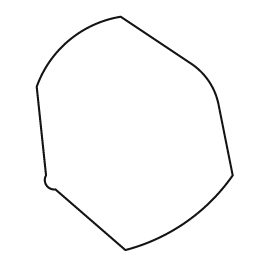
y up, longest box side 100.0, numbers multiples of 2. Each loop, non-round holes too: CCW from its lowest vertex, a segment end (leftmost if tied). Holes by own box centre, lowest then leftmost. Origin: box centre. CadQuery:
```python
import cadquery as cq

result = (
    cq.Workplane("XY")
    .moveTo(-4.0, -50.0)
    .threePointArc((22.0, -38.0), (42.0, -18.0))
    .lineTo(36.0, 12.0)
    .threePointArc((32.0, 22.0), (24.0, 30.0))
    .lineTo(-6.0, 50.0)
    .threePointArc((-28.0, 40.0), (-42.0, 20.0))
    .lineTo(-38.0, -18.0)
    .threePointArc((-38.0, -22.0), (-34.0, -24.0))
    .close()
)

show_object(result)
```